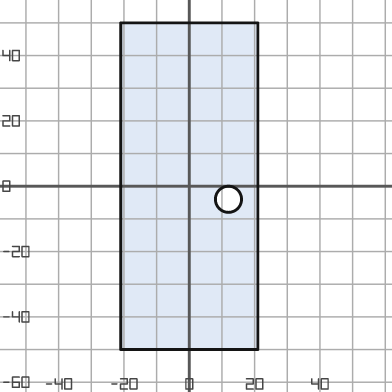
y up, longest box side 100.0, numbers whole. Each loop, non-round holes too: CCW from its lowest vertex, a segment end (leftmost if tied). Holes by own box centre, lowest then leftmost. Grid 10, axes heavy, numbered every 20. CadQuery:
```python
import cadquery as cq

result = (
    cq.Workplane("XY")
    .moveTo(-21.0, -50.0)
    .lineTo(21.0, -50.0)
    .lineTo(21.0, 50.0)
    .lineTo(-21.0, 50.0)
    .close()
    .moveTo(12.0, -4.0)
    .circle(4.0)
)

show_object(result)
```